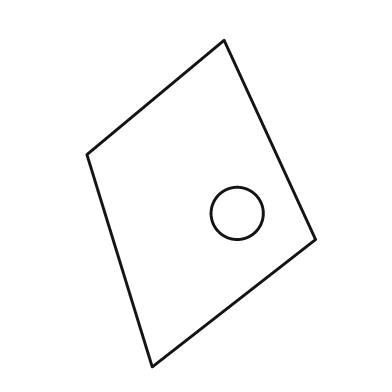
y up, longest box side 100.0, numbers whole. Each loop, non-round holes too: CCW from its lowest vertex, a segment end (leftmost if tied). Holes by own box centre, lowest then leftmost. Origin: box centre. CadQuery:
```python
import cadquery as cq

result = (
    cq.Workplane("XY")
    .moveTo(-15.0, -50.0)
    .lineTo(35.0, -11.0)
    .lineTo(7.0, 50.0)
    .lineTo(-35.0, 15.0)
    .close()
    .moveTo(11.0, -3.0)
    .circle(8.0)
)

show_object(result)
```